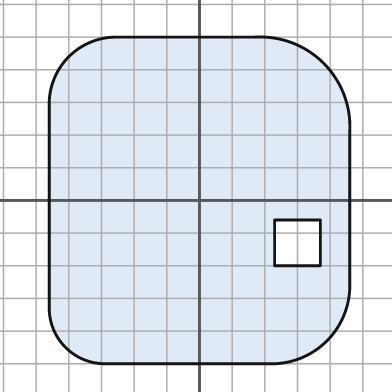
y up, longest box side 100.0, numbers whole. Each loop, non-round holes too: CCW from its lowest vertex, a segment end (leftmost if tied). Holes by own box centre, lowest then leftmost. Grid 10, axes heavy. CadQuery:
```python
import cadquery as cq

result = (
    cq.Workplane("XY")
    .moveTo(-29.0, -50.0)
    .lineTo(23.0, -50.0)
    .threePointArc((39.0, -43.0), (46.0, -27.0))
    .lineTo(46.0, 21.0)
    .threePointArc((38.0, 42.0), (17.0, 50.0))
    .lineTo(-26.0, 50.0)
    .threePointArc((-40.0, 44.0), (-46.0, 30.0))
    .lineTo(-46.0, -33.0)
    .threePointArc((-41.0, -45.0), (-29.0, -50.0))
    .close()
    .moveTo(23.0, -20.0)
    .lineTo(37.0, -20.0)
    .lineTo(37.0, -6.0)
    .lineTo(23.0, -6.0)
    .close()
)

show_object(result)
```